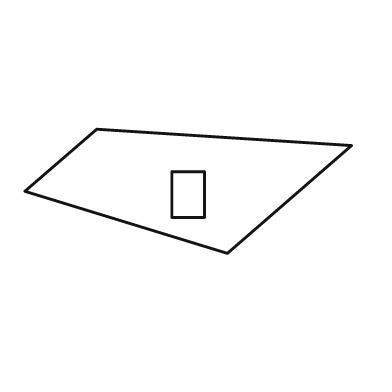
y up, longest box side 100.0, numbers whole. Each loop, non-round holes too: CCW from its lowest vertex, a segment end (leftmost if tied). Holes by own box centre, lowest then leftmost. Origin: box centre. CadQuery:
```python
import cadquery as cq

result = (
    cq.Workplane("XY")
    .moveTo(12.0, -19.0)
    .lineTo(50.0, 14.0)
    .lineTo(-28.0, 19.0)
    .lineTo(-50.0, 0.0)
    .close()
    .moveTo(-5.0, -8.0)
    .lineTo(5.0, -8.0)
    .lineTo(5.0, 6.0)
    .lineTo(-5.0, 6.0)
    .close()
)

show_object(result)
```